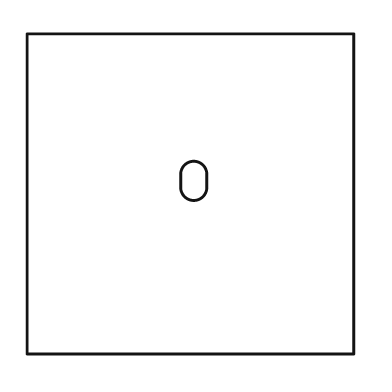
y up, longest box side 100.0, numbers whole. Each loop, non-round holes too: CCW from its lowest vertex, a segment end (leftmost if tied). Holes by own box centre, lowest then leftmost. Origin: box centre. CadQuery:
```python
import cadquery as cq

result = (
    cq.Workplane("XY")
    .moveTo(-50.0, -49.0)
    .lineTo(50.0, -49.0)
    .lineTo(50.0, 49.0)
    .lineTo(-50.0, 49.0)
    .close()
    .moveTo(-3.0, 2.0)
    .threePointArc((1.0, -2.0), (5.0, 2.0))
    .lineTo(5.0, 6.0)
    .threePointArc((1.0, 10.0), (-3.0, 6.0))
    .close()
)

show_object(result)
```